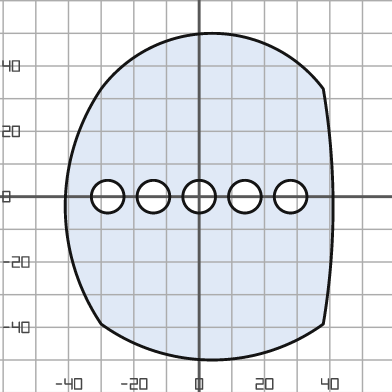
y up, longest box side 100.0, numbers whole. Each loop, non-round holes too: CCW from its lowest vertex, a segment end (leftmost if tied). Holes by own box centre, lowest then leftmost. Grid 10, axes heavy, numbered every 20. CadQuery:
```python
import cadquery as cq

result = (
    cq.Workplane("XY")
    .moveTo(-30.0, -39.0)
    .threePointArc((4.0, -50.0), (38.0, -39.0))
    .threePointArc((41.0, -3.0), (38.0, 33.0))
    .threePointArc((4.0, 50.0), (-30.0, 33.0))
    .threePointArc((-41.0, -3.0), (-30.0, -39.0))
    .close()
    .moveTo(-28.0, 0.0)
    .circle(5.0)
    .moveTo(-14.0, 0.0)
    .circle(5.0)
    .moveTo(0.0, 0.0)
    .circle(5.0)
    .moveTo(14.0, 0.0)
    .circle(5.0)
    .moveTo(28.0, 0.0)
    .circle(5.0)
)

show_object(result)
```